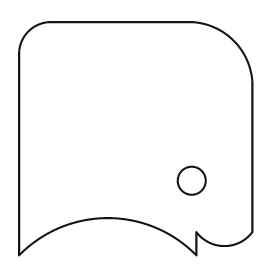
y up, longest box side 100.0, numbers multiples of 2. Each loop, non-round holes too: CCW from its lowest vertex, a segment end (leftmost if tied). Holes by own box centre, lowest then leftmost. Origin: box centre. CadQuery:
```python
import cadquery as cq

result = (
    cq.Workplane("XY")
    .moveTo(-50.0, -50.0)
    .threePointArc((-12.0, -34.0), (26.0, -50.0))
    .lineTo(26.0, -40.0)
    .threePointArc((38.0, -46.0), (50.0, -40.0))
    .lineTo(50.0, 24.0)
    .threePointArc((42.0, 42.0), (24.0, 50.0))
    .lineTo(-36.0, 50.0)
    .threePointArc((-46.0, 46.0), (-50.0, 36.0))
    .close()
    .moveTo(24.0, -18.0)
    .circle(6.0)
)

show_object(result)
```